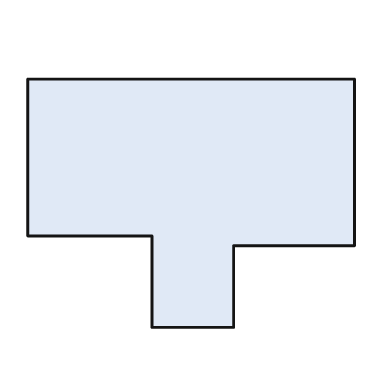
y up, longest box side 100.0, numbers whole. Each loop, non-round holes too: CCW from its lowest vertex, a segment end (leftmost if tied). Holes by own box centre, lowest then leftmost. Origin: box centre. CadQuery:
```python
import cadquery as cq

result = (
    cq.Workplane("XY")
    .moveTo(-12.0, -38.0)
    .lineTo(13.0, -38.0)
    .lineTo(13.0, -13.0)
    .lineTo(50.0, -13.0)
    .lineTo(50.0, 38.0)
    .lineTo(-50.0, 38.0)
    .lineTo(-50.0, -10.0)
    .lineTo(-12.0, -10.0)
    .close()
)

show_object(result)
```